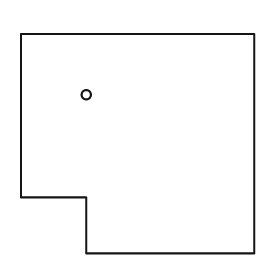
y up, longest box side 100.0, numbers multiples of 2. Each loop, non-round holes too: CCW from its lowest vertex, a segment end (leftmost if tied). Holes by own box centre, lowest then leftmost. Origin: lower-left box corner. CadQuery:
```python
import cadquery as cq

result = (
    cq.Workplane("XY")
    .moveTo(28.0, 0.0)
    .lineTo(100.0, 0.0)
    .lineTo(100.0, 94.0)
    .lineTo(0.0, 94.0)
    .lineTo(0.0, 24.0)
    .lineTo(28.0, 24.0)
    .close()
    .moveTo(28.0, 68.0)
    .circle(2.0)
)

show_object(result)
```